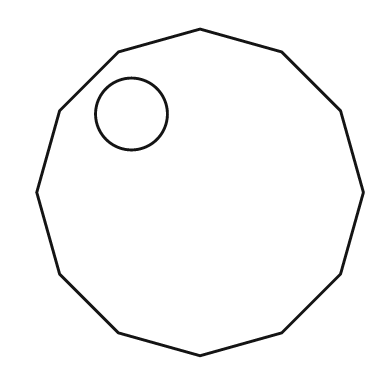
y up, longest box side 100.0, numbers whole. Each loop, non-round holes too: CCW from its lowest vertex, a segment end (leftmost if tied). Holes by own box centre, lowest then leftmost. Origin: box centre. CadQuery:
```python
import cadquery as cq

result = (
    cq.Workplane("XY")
    .moveTo(0.0, -50.0)
    .lineTo(25.0, -43.0)
    .lineTo(43.0, -25.0)
    .lineTo(50.0, 0.0)
    .lineTo(43.0, 25.0)
    .lineTo(25.0, 43.0)
    .lineTo(0.0, 50.0)
    .lineTo(-25.0, 43.0)
    .lineTo(-43.0, 25.0)
    .lineTo(-50.0, 0.0)
    .lineTo(-43.0, -25.0)
    .lineTo(-25.0, -43.0)
    .close()
    .moveTo(-21.0, 24.0)
    .circle(11.0)
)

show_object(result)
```